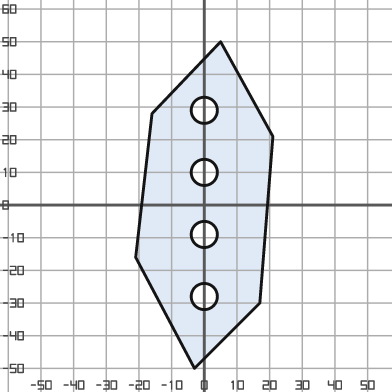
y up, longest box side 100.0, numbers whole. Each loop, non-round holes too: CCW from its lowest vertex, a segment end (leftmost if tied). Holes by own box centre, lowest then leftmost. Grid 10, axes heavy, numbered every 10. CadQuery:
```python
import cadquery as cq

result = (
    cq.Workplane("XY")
    .moveTo(-3.0, -50.0)
    .lineTo(17.0, -30.0)
    .lineTo(21.0, 21.0)
    .lineTo(5.0, 50.0)
    .lineTo(-16.0, 28.0)
    .lineTo(-21.0, -16.0)
    .close()
    .moveTo(0.0, -28.0)
    .circle(4.0)
    .moveTo(0.0, -9.0)
    .circle(4.0)
    .moveTo(0.0, 10.0)
    .circle(4.0)
    .moveTo(0.0, 29.0)
    .circle(4.0)
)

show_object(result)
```